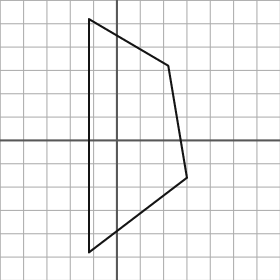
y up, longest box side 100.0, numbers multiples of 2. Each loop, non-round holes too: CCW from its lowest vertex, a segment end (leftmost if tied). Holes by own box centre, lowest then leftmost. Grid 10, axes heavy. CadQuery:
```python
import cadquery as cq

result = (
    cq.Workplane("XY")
    .moveTo(-12.0, -48.0)
    .lineTo(30.0, -16.0)
    .lineTo(22.0, 32.0)
    .lineTo(-12.0, 52.0)
    .close()
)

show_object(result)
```